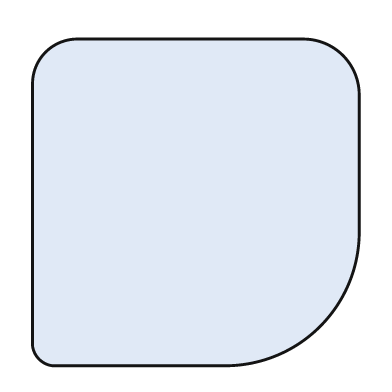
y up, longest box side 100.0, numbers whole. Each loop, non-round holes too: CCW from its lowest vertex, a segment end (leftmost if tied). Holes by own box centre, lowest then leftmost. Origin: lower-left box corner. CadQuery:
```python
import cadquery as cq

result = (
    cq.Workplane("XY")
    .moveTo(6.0, 0.0)
    .lineTo(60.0, 0.0)
    .threePointArc((88.0, 12.0), (100.0, 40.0))
    .lineTo(100.0, 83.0)
    .threePointArc((95.0, 95.0), (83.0, 100.0))
    .lineTo(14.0, 100.0)
    .threePointArc((4.0, 96.0), (0.0, 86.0))
    .lineTo(0.0, 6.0)
    .threePointArc((2.0, 2.0), (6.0, 0.0))
    .close()
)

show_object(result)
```